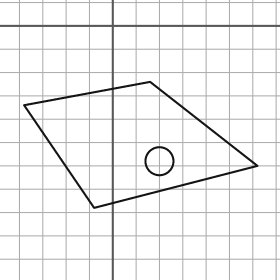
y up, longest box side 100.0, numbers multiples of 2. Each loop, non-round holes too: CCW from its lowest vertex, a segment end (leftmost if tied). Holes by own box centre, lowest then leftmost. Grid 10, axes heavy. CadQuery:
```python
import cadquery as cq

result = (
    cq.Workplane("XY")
    .moveTo(-8.0, -78.0)
    .lineTo(62.0, -60.0)
    .lineTo(16.0, -24.0)
    .lineTo(-38.0, -34.0)
    .close()
    .moveTo(20.0, -58.0)
    .circle(6.0)
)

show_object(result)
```